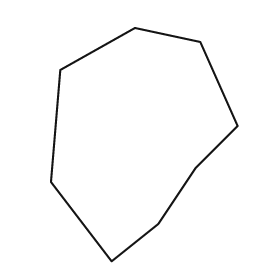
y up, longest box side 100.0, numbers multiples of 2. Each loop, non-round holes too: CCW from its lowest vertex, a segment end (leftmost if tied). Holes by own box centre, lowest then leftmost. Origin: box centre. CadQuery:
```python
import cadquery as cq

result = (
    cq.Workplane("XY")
    .moveTo(-14.0, -50.0)
    .lineTo(6.0, -34.0)
    .lineTo(22.0, -10.0)
    .lineTo(40.0, 8.0)
    .lineTo(24.0, 44.0)
    .lineTo(-4.0, 50.0)
    .lineTo(-36.0, 32.0)
    .lineTo(-40.0, -16.0)
    .close()
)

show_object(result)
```